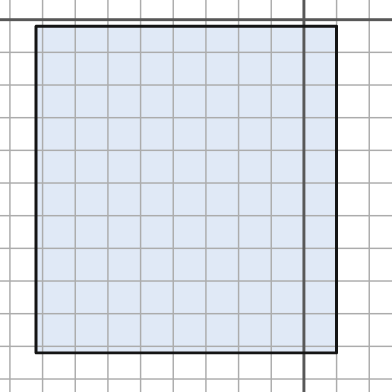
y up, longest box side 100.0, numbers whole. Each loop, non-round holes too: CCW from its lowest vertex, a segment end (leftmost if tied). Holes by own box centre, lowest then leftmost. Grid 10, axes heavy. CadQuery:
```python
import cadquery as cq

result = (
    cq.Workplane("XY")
    .moveTo(-82.0, -102.0)
    .lineTo(10.0, -102.0)
    .lineTo(10.0, -2.0)
    .lineTo(-82.0, -2.0)
    .close()
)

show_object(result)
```